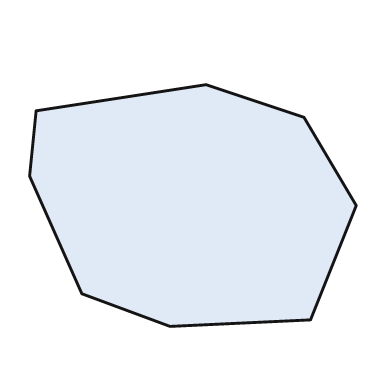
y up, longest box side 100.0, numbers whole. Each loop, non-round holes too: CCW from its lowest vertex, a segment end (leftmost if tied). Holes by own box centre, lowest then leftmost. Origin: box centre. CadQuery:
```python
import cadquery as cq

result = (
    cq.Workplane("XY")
    .moveTo(-7.0, -37.0)
    .lineTo(36.0, -35.0)
    .lineTo(50.0, 0.0)
    .lineTo(34.0, 27.0)
    .lineTo(4.0, 37.0)
    .lineTo(-48.0, 29.0)
    .lineTo(-50.0, 9.0)
    .lineTo(-34.0, -27.0)
    .close()
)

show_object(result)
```